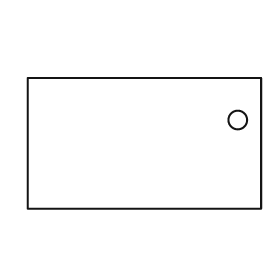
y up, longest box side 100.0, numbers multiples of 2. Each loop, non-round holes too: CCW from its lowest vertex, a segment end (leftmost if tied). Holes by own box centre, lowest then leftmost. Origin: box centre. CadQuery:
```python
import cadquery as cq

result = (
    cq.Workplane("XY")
    .moveTo(-50.0, -28.0)
    .lineTo(50.0, -28.0)
    .lineTo(50.0, 28.0)
    .lineTo(-50.0, 28.0)
    .close()
    .moveTo(40.0, 10.0)
    .circle(4.0)
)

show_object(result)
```